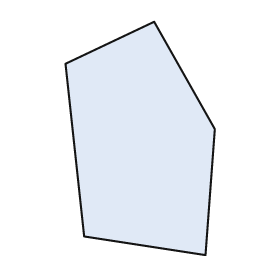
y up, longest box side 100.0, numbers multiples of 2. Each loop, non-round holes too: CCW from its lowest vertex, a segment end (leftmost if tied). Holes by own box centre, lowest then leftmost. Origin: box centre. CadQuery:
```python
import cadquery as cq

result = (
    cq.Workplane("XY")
    .moveTo(28.0, -50.0)
    .lineTo(32.0, 4.0)
    .lineTo(6.0, 50.0)
    .lineTo(-32.0, 32.0)
    .lineTo(-24.0, -42.0)
    .close()
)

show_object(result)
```